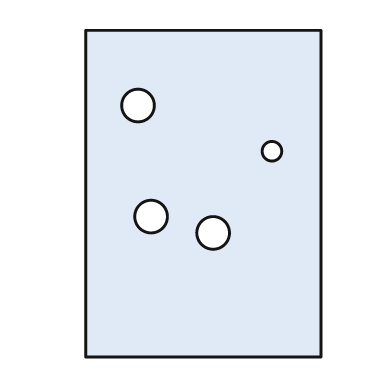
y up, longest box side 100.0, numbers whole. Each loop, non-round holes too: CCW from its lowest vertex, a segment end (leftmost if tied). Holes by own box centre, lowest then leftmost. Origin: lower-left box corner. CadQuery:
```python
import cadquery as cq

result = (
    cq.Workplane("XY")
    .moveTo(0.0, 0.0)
    .lineTo(72.0, 0.0)
    .lineTo(72.0, 100.0)
    .lineTo(0.0, 100.0)
    .close()
    .moveTo(39.0, 38.0)
    .circle(5.0)
    .moveTo(20.0, 43.0)
    .circle(5.0)
    .moveTo(57.0, 63.0)
    .circle(3.0)
    .moveTo(16.0, 77.0)
    .circle(5.0)
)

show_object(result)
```